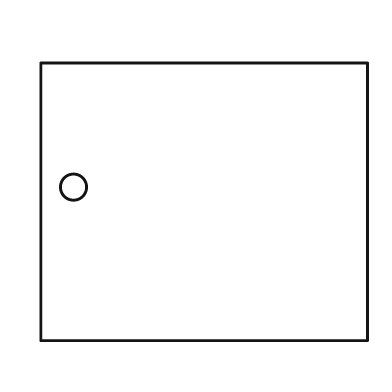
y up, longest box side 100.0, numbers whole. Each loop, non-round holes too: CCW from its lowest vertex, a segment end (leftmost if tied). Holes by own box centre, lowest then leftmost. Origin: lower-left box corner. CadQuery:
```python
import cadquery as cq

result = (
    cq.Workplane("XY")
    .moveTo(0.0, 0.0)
    .lineTo(100.0, 0.0)
    .lineTo(100.0, 85.0)
    .lineTo(0.0, 85.0)
    .close()
    .moveTo(10.0, 47.0)
    .circle(4.0)
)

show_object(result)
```